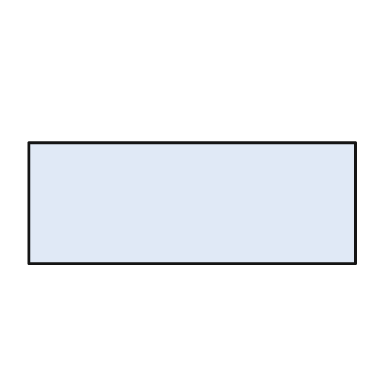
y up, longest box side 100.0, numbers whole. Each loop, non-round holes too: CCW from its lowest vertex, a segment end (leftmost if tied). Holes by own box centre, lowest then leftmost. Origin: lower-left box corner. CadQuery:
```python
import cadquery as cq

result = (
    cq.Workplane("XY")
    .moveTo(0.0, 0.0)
    .lineTo(100.0, 0.0)
    .lineTo(100.0, 37.0)
    .lineTo(0.0, 37.0)
    .close()
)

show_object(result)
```